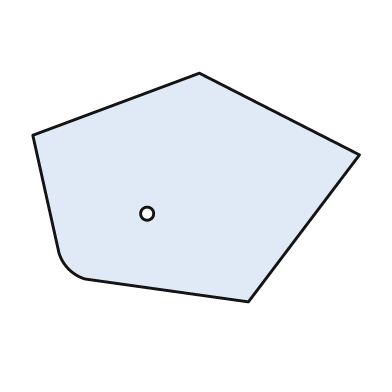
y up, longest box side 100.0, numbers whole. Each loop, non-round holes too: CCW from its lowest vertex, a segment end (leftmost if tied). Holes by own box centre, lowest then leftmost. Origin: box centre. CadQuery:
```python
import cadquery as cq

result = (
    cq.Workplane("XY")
    .moveTo(16.0, -35.0)
    .lineTo(50.0, 10.0)
    .lineTo(1.0, 35.0)
    .lineTo(-50.0, 16.0)
    .lineTo(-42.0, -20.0)
    .threePointArc((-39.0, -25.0), (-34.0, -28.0))
    .close()
    .moveTo(-15.0, -8.0)
    .circle(2.0)
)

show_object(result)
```